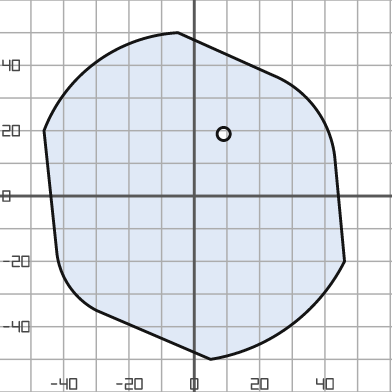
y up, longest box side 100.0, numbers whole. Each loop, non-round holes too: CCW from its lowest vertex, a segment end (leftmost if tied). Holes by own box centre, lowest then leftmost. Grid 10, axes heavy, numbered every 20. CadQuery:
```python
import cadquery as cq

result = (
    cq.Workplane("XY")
    .moveTo(5.0, -50.0)
    .threePointArc((29.0, -40.0), (46.0, -20.0))
    .lineTo(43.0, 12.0)
    .threePointArc((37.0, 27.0), (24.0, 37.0))
    .lineTo(-5.0, 50.0)
    .threePointArc((-30.0, 41.0), (-46.0, 20.0))
    .lineTo(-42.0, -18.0)
    .threePointArc((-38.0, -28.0), (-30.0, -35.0))
    .close()
    .moveTo(9.0, 19.0)
    .circle(2.0)
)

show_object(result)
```